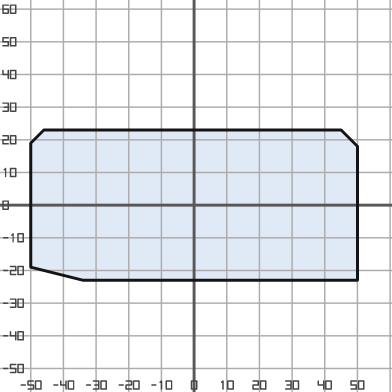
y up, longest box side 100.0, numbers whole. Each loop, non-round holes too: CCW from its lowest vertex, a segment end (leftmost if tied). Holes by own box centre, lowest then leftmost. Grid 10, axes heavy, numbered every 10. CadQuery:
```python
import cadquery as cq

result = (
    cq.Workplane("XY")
    .moveTo(-34.0, -23.0)
    .lineTo(50.0, -23.0)
    .lineTo(50.0, 18.0)
    .lineTo(45.0, 23.0)
    .lineTo(-46.0, 23.0)
    .lineTo(-50.0, 19.0)
    .lineTo(-50.0, -19.0)
    .close()
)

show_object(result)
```